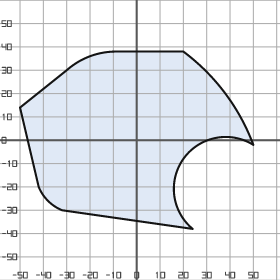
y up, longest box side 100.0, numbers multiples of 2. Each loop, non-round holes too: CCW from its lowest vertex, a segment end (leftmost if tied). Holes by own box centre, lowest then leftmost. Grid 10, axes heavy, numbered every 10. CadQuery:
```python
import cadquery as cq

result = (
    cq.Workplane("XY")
    .moveTo(24.0, -38.0)
    .threePointArc((20.0, -8.0), (50.0, -2.0))
    .threePointArc((38.0, 20.0), (20.0, 38.0))
    .lineTo(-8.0, 38.0)
    .threePointArc((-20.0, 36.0), (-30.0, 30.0))
    .lineTo(-50.0, 14.0)
    .lineTo(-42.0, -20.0)
    .threePointArc((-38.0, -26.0), (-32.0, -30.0))
    .close()
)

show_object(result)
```